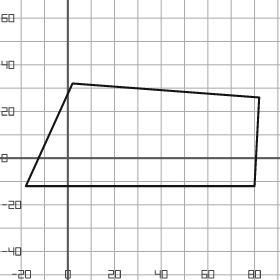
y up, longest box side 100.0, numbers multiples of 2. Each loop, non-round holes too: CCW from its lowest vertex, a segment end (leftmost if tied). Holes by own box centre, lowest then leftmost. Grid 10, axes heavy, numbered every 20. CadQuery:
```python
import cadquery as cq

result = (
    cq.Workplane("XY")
    .moveTo(-18.0, -12.0)
    .lineTo(80.0, -12.0)
    .lineTo(82.0, 26.0)
    .lineTo(2.0, 32.0)
    .close()
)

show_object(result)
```